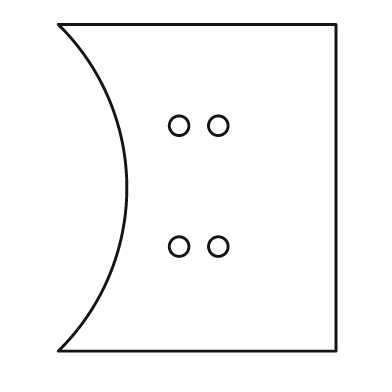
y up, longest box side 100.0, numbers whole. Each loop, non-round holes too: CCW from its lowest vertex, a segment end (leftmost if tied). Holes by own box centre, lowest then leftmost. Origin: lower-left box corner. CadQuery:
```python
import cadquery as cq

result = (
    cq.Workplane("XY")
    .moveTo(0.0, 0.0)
    .lineTo(85.0, 0.0)
    .lineTo(85.0, 100.0)
    .lineTo(0.0, 100.0)
    .threePointArc((21.0, 50.0), (0.0, 0.0))
    .close()
    .moveTo(37.0, 32.0)
    .circle(3.0)
    .moveTo(49.0, 32.0)
    .circle(3.0)
    .moveTo(37.0, 69.0)
    .circle(3.0)
    .moveTo(49.0, 69.0)
    .circle(3.0)
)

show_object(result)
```